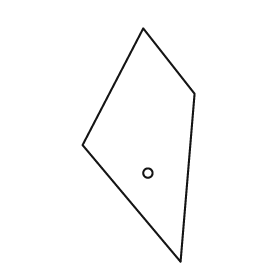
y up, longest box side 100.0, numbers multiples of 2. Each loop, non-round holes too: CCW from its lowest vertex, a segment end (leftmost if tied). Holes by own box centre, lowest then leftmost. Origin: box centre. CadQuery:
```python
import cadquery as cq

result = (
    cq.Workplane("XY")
    .moveTo(18.0, -50.0)
    .lineTo(24.0, 22.0)
    .lineTo(2.0, 50.0)
    .lineTo(-24.0, 0.0)
    .close()
    .moveTo(4.0, -12.0)
    .circle(2.0)
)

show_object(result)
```